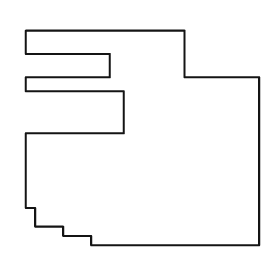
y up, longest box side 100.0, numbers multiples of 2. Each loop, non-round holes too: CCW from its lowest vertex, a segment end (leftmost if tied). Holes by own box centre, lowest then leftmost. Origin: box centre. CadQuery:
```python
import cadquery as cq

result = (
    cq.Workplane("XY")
    .moveTo(-22.0, -46.0)
    .lineTo(50.0, -46.0)
    .lineTo(50.0, 26.0)
    .lineTo(18.0, 26.0)
    .lineTo(18.0, 46.0)
    .lineTo(-50.0, 46.0)
    .lineTo(-50.0, 36.0)
    .lineTo(-14.0, 36.0)
    .lineTo(-14.0, 26.0)
    .lineTo(-50.0, 26.0)
    .lineTo(-50.0, 20.0)
    .lineTo(-8.0, 20.0)
    .lineTo(-8.0, 2.0)
    .lineTo(-50.0, 2.0)
    .lineTo(-50.0, -30.0)
    .lineTo(-46.0, -30.0)
    .lineTo(-46.0, -38.0)
    .lineTo(-34.0, -38.0)
    .lineTo(-34.0, -42.0)
    .lineTo(-22.0, -42.0)
    .close()
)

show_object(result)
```